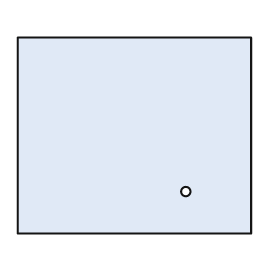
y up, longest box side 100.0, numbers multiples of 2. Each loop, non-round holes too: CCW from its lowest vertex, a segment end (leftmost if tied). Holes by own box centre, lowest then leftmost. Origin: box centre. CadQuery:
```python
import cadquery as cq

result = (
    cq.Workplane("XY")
    .moveTo(-50.0, -42.0)
    .lineTo(50.0, -42.0)
    .lineTo(50.0, 42.0)
    .lineTo(-50.0, 42.0)
    .close()
    .moveTo(22.0, -24.0)
    .circle(2.0)
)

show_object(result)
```